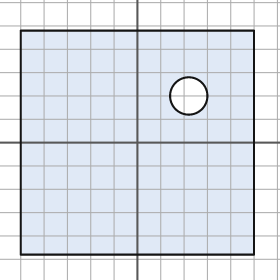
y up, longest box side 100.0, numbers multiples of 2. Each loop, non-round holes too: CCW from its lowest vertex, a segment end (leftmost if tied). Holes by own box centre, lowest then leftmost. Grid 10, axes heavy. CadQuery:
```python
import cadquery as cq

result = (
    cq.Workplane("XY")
    .moveTo(-50.0, -48.0)
    .lineTo(50.0, -48.0)
    .lineTo(50.0, 48.0)
    .lineTo(-50.0, 48.0)
    .close()
    .moveTo(22.0, 20.0)
    .circle(8.0)
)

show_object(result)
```